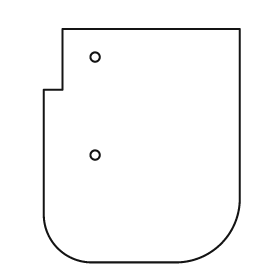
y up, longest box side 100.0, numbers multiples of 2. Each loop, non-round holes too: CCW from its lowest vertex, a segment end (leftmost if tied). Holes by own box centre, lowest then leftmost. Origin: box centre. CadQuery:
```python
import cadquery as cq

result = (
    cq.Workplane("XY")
    .moveTo(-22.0, -50.0)
    .lineTo(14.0, -50.0)
    .threePointArc((34.0, -42.0), (42.0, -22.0))
    .lineTo(42.0, 50.0)
    .lineTo(-34.0, 50.0)
    .lineTo(-34.0, 24.0)
    .lineTo(-42.0, 24.0)
    .lineTo(-42.0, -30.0)
    .threePointArc((-36.0, -44.0), (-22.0, -50.0))
    .close()
    .moveTo(-20.0, -4.0)
    .circle(2.0)
    .moveTo(-20.0, 38.0)
    .circle(2.0)
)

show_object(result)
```